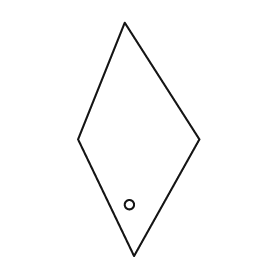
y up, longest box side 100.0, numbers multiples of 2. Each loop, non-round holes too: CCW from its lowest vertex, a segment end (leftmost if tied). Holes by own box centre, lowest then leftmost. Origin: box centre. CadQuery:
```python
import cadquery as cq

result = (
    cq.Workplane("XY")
    .moveTo(-2.0, -50.0)
    .lineTo(26.0, 0.0)
    .lineTo(-6.0, 50.0)
    .lineTo(-26.0, 0.0)
    .close()
    .moveTo(-4.0, -28.0)
    .circle(2.0)
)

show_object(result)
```